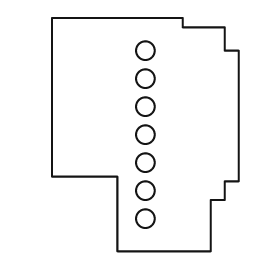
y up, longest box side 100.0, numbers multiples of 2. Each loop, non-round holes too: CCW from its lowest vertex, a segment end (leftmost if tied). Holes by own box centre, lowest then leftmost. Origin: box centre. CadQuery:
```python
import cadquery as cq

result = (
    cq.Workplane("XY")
    .moveTo(-12.0, -50.0)
    .lineTo(28.0, -50.0)
    .lineTo(28.0, -28.0)
    .lineTo(34.0, -28.0)
    .lineTo(34.0, -20.0)
    .lineTo(40.0, -20.0)
    .lineTo(40.0, 36.0)
    .lineTo(34.0, 36.0)
    .lineTo(34.0, 46.0)
    .lineTo(16.0, 46.0)
    .lineTo(16.0, 50.0)
    .lineTo(-40.0, 50.0)
    .lineTo(-40.0, -18.0)
    .lineTo(-12.0, -18.0)
    .close()
    .moveTo(0.0, -36.0)
    .circle(4.0)
    .moveTo(0.0, -24.0)
    .circle(4.0)
    .moveTo(0.0, -12.0)
    .circle(4.0)
    .moveTo(0.0, 0.0)
    .circle(4.0)
    .moveTo(0.0, 12.0)
    .circle(4.0)
    .moveTo(0.0, 24.0)
    .circle(4.0)
    .moveTo(0.0, 36.0)
    .circle(4.0)
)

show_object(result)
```